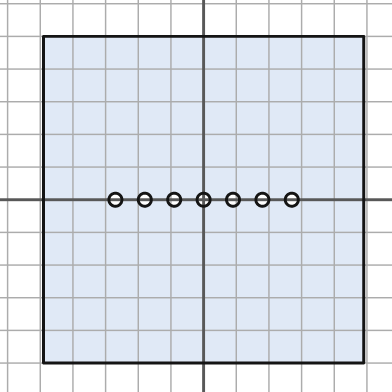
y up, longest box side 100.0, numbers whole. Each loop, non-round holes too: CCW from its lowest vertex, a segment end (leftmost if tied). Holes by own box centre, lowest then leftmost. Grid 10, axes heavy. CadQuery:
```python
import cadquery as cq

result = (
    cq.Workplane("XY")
    .moveTo(-49.0, -50.0)
    .lineTo(49.0, -50.0)
    .lineTo(49.0, 50.0)
    .lineTo(-49.0, 50.0)
    .close()
    .moveTo(-27.0, 0.0)
    .circle(2.0)
    .moveTo(-18.0, 0.0)
    .circle(2.0)
    .moveTo(-9.0, 0.0)
    .circle(2.0)
    .moveTo(0.0, 0.0)
    .circle(2.0)
    .moveTo(9.0, 0.0)
    .circle(2.0)
    .moveTo(18.0, 0.0)
    .circle(2.0)
    .moveTo(27.0, 0.0)
    .circle(2.0)
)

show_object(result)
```